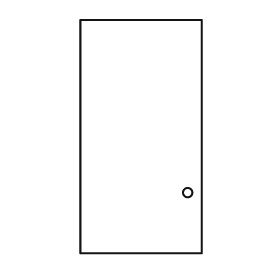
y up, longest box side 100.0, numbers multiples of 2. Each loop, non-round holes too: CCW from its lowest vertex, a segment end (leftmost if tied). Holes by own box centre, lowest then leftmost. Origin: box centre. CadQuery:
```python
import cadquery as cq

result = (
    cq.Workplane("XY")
    .moveTo(-26.0, -50.0)
    .lineTo(26.0, -50.0)
    .lineTo(26.0, 50.0)
    .lineTo(-26.0, 50.0)
    .close()
    .moveTo(20.0, -24.0)
    .circle(2.0)
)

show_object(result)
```